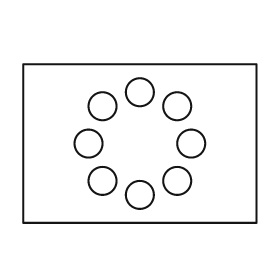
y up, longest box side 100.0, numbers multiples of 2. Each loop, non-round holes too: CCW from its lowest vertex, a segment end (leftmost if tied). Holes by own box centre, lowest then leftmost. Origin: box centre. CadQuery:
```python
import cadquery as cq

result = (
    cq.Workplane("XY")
    .moveTo(-50.0, -34.0)
    .lineTo(50.0, -34.0)
    .lineTo(50.0, 34.0)
    .lineTo(-50.0, 34.0)
    .close()
    .moveTo(0.0, -22.0)
    .circle(6.0)
    .moveTo(-16.0, -16.0)
    .circle(6.0)
    .moveTo(16.0, -16.0)
    .circle(6.0)
    .moveTo(-22.0, 0.0)
    .circle(6.0)
    .moveTo(22.0, 0.0)
    .circle(6.0)
    .moveTo(-16.0, 16.0)
    .circle(6.0)
    .moveTo(16.0, 16.0)
    .circle(6.0)
    .moveTo(0.0, 22.0)
    .circle(6.0)
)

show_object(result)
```